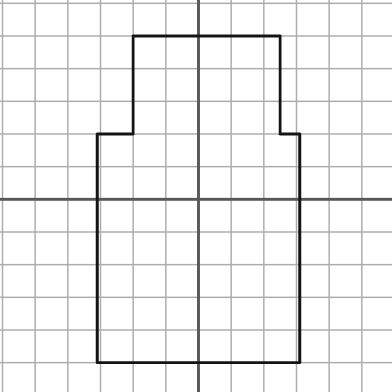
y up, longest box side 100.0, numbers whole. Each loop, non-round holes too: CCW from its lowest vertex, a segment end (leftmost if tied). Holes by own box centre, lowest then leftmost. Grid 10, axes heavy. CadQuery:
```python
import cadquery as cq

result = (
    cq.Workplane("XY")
    .moveTo(-31.0, -50.0)
    .lineTo(31.0, -50.0)
    .lineTo(31.0, 20.0)
    .lineTo(25.0, 20.0)
    .lineTo(25.0, 50.0)
    .lineTo(-20.0, 50.0)
    .lineTo(-20.0, 20.0)
    .lineTo(-31.0, 20.0)
    .close()
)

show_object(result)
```